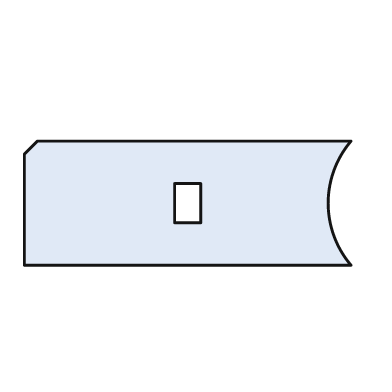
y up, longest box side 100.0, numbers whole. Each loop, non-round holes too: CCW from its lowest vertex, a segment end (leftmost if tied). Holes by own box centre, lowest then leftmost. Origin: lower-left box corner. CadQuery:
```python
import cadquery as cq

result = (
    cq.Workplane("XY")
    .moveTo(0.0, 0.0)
    .lineTo(100.0, 0.0)
    .threePointArc((93.0, 19.0), (100.0, 38.0))
    .lineTo(4.0, 38.0)
    .lineTo(0.0, 34.0)
    .close()
    .moveTo(46.0, 13.0)
    .lineTo(54.0, 13.0)
    .lineTo(54.0, 25.0)
    .lineTo(46.0, 25.0)
    .close()
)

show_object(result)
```